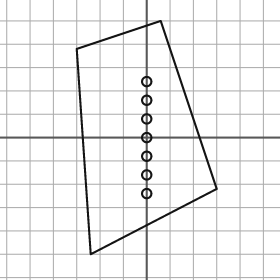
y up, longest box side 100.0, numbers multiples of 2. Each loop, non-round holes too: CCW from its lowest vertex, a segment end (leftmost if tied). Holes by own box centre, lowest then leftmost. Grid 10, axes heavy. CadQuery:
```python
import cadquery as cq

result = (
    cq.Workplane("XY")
    .moveTo(-24.0, -50.0)
    .lineTo(30.0, -22.0)
    .lineTo(6.0, 50.0)
    .lineTo(-30.0, 38.0)
    .close()
    .moveTo(0.0, -24.0)
    .circle(2.0)
    .moveTo(0.0, -16.0)
    .circle(2.0)
    .moveTo(0.0, -8.0)
    .circle(2.0)
    .moveTo(0.0, 0.0)
    .circle(2.0)
    .moveTo(0.0, 8.0)
    .circle(2.0)
    .moveTo(0.0, 16.0)
    .circle(2.0)
    .moveTo(0.0, 24.0)
    .circle(2.0)
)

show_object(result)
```